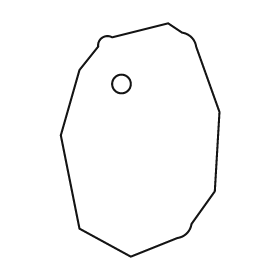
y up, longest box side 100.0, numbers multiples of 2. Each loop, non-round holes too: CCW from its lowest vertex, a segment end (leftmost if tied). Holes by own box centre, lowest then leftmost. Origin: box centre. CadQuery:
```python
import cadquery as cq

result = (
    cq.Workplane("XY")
    .moveTo(-4.0, -50.0)
    .lineTo(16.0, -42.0)
    .threePointArc((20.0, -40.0), (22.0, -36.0))
    .lineTo(32.0, -22.0)
    .lineTo(34.0, 12.0)
    .lineTo(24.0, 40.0)
    .threePointArc((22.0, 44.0), (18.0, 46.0))
    .lineTo(12.0, 50.0)
    .lineTo(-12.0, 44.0)
    .threePointArc((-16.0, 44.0), (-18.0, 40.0))
    .lineTo(-26.0, 30.0)
    .lineTo(-34.0, 2.0)
    .lineTo(-26.0, -38.0)
    .close()
    .moveTo(-8.0, 24.0)
    .circle(4.0)
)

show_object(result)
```